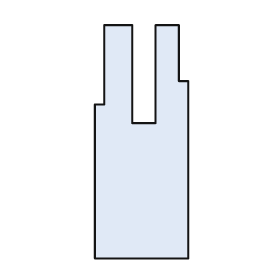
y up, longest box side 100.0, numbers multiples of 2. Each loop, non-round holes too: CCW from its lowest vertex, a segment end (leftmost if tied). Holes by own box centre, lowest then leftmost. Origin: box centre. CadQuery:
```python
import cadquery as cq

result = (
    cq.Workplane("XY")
    .moveTo(-20.0, -50.0)
    .lineTo(20.0, -50.0)
    .lineTo(20.0, 26.0)
    .lineTo(16.0, 26.0)
    .lineTo(16.0, 50.0)
    .lineTo(6.0, 50.0)
    .lineTo(6.0, 8.0)
    .lineTo(-4.0, 8.0)
    .lineTo(-4.0, 50.0)
    .lineTo(-16.0, 50.0)
    .lineTo(-16.0, 16.0)
    .lineTo(-20.0, 16.0)
    .close()
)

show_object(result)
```